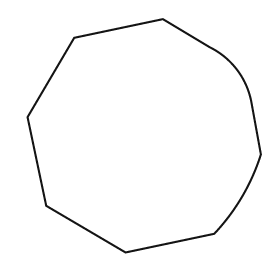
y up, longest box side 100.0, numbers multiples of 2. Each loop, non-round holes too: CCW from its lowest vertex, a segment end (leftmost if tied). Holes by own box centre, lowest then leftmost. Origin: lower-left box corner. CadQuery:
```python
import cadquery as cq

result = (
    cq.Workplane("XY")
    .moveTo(42.0, 0.0)
    .lineTo(80.0, 8.0)
    .threePointArc((92.0, 24.0), (100.0, 42.0))
    .lineTo(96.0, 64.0)
    .threePointArc((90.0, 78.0), (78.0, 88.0))
    .lineTo(58.0, 100.0)
    .lineTo(20.0, 92.0)
    .lineTo(0.0, 58.0)
    .lineTo(8.0, 20.0)
    .close()
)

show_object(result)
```